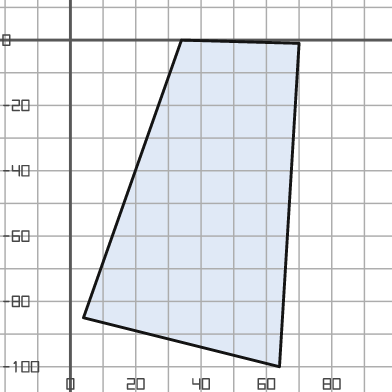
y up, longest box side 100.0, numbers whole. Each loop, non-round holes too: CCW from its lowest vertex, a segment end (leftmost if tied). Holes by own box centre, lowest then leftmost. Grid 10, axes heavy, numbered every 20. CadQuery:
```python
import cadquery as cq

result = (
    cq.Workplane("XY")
    .moveTo(64.0, -100.0)
    .lineTo(70.0, -1.0)
    .lineTo(34.0, 0.0)
    .lineTo(4.0, -85.0)
    .close()
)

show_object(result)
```